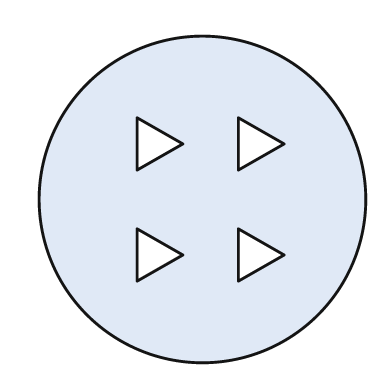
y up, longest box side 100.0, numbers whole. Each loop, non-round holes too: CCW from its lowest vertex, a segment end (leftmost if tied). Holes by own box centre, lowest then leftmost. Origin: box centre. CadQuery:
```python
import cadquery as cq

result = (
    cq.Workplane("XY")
    .moveTo(0.0, 0.0)
    .circle(50.0)
    .moveTo(-20.0, -25.0)
    .lineTo(-6.0, -17.0)
    .lineTo(-20.0, -9.0)
    .close()
    .moveTo(11.0, -25.0)
    .lineTo(25.0, -17.0)
    .lineTo(11.0, -9.0)
    .close()
    .moveTo(-20.0, 9.0)
    .lineTo(-6.0, 17.0)
    .lineTo(-20.0, 25.0)
    .close()
    .moveTo(11.0, 9.0)
    .lineTo(25.0, 17.0)
    .lineTo(11.0, 25.0)
    .close()
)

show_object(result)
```